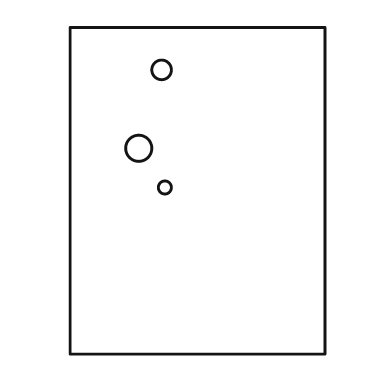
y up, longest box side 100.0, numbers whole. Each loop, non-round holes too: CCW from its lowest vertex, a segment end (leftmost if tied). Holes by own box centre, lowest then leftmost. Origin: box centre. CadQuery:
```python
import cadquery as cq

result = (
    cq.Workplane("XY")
    .moveTo(-39.0, -50.0)
    .lineTo(39.0, -50.0)
    .lineTo(39.0, 50.0)
    .lineTo(-39.0, 50.0)
    .close()
    .moveTo(-10.0, 1.0)
    .circle(2.0)
    .moveTo(-18.0, 13.0)
    .circle(4.0)
    .moveTo(-11.0, 37.0)
    .circle(3.0)
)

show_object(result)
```